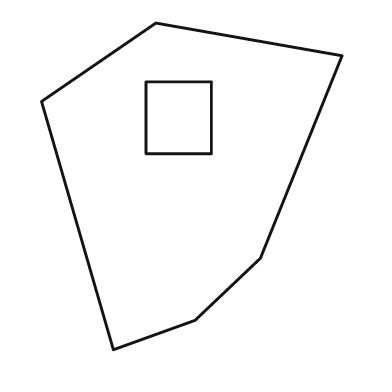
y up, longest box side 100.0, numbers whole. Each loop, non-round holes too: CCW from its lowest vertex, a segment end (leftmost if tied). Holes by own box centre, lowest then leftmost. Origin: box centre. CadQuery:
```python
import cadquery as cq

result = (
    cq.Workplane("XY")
    .moveTo(-24.0, -50.0)
    .lineTo(1.0, -41.0)
    .lineTo(21.0, -22.0)
    .lineTo(46.0, 40.0)
    .lineTo(-11.0, 50.0)
    .lineTo(-46.0, 26.0)
    .close()
    .moveTo(-14.0, 10.0)
    .lineTo(6.0, 10.0)
    .lineTo(6.0, 32.0)
    .lineTo(-14.0, 32.0)
    .close()
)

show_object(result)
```